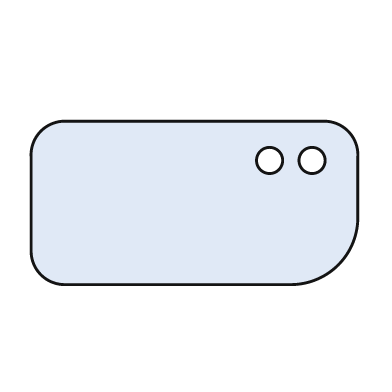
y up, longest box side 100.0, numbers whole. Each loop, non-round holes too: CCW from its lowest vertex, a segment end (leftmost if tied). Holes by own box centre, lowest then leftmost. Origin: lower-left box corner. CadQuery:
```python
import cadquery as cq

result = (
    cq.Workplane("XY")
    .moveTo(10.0, 0.0)
    .lineTo(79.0, 0.0)
    .threePointArc((94.0, 6.0), (100.0, 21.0))
    .lineTo(100.0, 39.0)
    .threePointArc((97.0, 47.0), (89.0, 50.0))
    .lineTo(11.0, 50.0)
    .threePointArc((3.0, 47.0), (0.0, 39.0))
    .lineTo(0.0, 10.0)
    .threePointArc((3.0, 3.0), (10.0, 0.0))
    .close()
    .moveTo(73.0, 38.0)
    .circle(4.0)
    .moveTo(86.0, 38.0)
    .circle(4.0)
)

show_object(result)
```